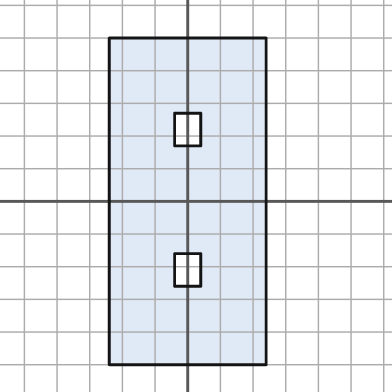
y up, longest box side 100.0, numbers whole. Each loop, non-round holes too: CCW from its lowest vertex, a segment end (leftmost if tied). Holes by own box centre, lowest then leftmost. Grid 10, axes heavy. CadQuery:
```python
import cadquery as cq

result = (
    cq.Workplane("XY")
    .moveTo(-24.0, -50.0)
    .lineTo(24.0, -50.0)
    .lineTo(24.0, 50.0)
    .lineTo(-24.0, 50.0)
    .close()
    .moveTo(-4.0, -26.0)
    .lineTo(4.0, -26.0)
    .lineTo(4.0, -16.0)
    .lineTo(-4.0, -16.0)
    .close()
    .moveTo(-4.0, 17.0)
    .lineTo(4.0, 17.0)
    .lineTo(4.0, 27.0)
    .lineTo(-4.0, 27.0)
    .close()
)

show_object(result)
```